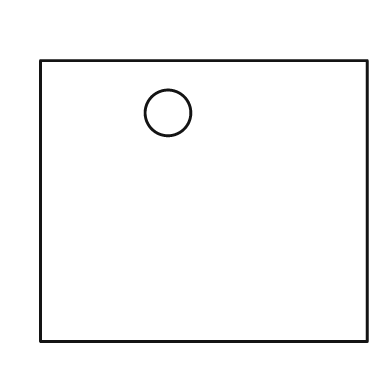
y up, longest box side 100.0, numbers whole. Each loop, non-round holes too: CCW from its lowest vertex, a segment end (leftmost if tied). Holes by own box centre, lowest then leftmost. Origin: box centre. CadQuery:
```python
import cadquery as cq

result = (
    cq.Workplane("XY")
    .moveTo(-50.0, -43.0)
    .lineTo(50.0, -43.0)
    .lineTo(50.0, 43.0)
    .lineTo(-50.0, 43.0)
    .close()
    .moveTo(-11.0, 27.0)
    .circle(7.0)
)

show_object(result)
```